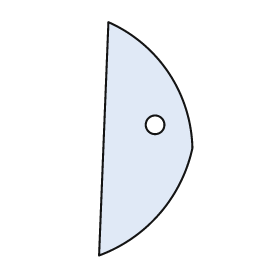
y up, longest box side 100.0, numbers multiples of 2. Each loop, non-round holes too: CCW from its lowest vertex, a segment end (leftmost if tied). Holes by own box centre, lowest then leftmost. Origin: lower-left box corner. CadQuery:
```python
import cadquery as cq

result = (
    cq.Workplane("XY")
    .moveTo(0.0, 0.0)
    .threePointArc((26.0, 18.0), (40.0, 46.0))
    .threePointArc((30.0, 78.0), (4.0, 100.0))
    .close()
    .moveTo(24.0, 56.0)
    .circle(4.0)
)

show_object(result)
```